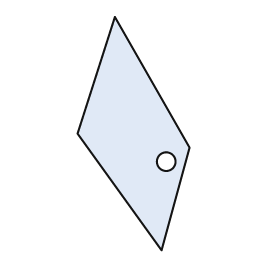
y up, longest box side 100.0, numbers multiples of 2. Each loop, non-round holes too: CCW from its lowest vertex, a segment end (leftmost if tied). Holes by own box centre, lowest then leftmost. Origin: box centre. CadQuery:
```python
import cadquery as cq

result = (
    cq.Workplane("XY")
    .moveTo(12.0, -50.0)
    .lineTo(24.0, -6.0)
    .lineTo(-8.0, 50.0)
    .lineTo(-24.0, 0.0)
    .close()
    .moveTo(14.0, -12.0)
    .circle(4.0)
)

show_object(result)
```